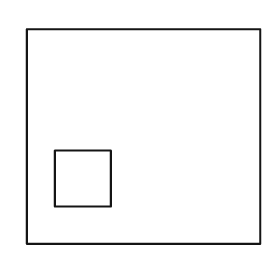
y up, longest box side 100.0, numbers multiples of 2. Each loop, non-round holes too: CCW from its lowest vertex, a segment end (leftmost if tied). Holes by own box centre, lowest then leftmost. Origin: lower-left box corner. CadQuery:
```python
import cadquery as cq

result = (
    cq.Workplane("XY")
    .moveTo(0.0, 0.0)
    .lineTo(100.0, 0.0)
    .lineTo(100.0, 92.0)
    .lineTo(0.0, 92.0)
    .close()
    .moveTo(12.0, 16.0)
    .lineTo(36.0, 16.0)
    .lineTo(36.0, 40.0)
    .lineTo(12.0, 40.0)
    .close()
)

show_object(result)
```